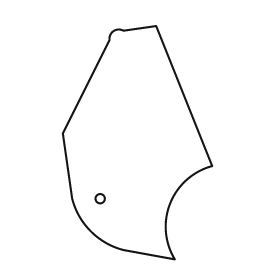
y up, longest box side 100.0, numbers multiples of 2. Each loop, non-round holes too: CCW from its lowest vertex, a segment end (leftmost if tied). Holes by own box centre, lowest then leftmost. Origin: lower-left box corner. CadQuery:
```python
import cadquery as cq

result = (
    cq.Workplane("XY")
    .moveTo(48.0, 0.0)
    .threePointArc((46.0, 24.0), (64.0, 40.0))
    .lineTo(40.0, 100.0)
    .lineTo(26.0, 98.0)
    .threePointArc((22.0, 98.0), (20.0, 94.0))
    .lineTo(0.0, 54.0)
    .lineTo(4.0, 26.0)
    .threePointArc((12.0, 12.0), (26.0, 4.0))
    .close()
    .moveTo(16.0, 26.0)
    .circle(2.0)
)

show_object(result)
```